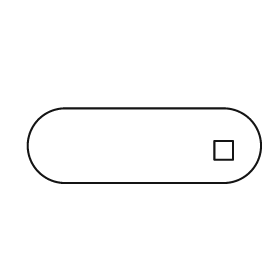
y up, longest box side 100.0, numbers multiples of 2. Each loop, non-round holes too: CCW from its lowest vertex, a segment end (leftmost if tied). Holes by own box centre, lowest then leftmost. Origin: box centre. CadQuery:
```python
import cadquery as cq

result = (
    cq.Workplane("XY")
    .moveTo(-34.0, -16.0)
    .lineTo(34.0, -16.0)
    .threePointArc((50.0, 0.0), (34.0, 16.0))
    .lineTo(-34.0, 16.0)
    .threePointArc((-50.0, 0.0), (-34.0, -16.0))
    .close()
    .moveTo(30.0, -6.0)
    .lineTo(38.0, -6.0)
    .lineTo(38.0, 2.0)
    .lineTo(30.0, 2.0)
    .close()
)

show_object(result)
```